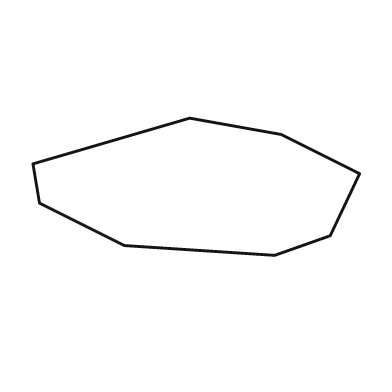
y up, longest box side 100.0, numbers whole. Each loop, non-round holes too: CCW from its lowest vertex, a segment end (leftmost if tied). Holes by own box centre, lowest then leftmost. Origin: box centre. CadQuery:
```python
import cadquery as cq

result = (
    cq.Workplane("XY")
    .moveTo(24.0, -21.0)
    .lineTo(41.0, -15.0)
    .lineTo(50.0, 4.0)
    .lineTo(26.0, 16.0)
    .lineTo(-2.0, 21.0)
    .lineTo(-50.0, 7.0)
    .lineTo(-48.0, -5.0)
    .lineTo(-22.0, -18.0)
    .close()
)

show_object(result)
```